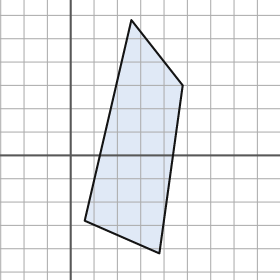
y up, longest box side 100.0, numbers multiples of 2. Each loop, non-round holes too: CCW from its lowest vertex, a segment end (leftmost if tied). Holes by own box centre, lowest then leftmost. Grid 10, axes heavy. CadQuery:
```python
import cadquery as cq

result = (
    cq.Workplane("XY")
    .moveTo(38.0, -42.0)
    .lineTo(48.0, 30.0)
    .lineTo(26.0, 58.0)
    .lineTo(6.0, -28.0)
    .close()
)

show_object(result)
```